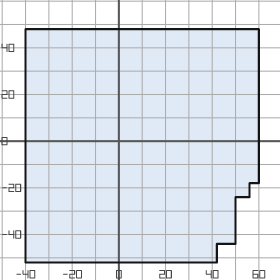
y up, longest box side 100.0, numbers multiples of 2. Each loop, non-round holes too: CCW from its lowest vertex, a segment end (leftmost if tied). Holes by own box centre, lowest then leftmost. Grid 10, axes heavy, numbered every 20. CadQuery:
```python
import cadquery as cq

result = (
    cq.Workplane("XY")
    .moveTo(-40.0, -52.0)
    .lineTo(42.0, -52.0)
    .lineTo(42.0, -44.0)
    .lineTo(50.0, -44.0)
    .lineTo(50.0, -24.0)
    .lineTo(56.0, -24.0)
    .lineTo(56.0, -18.0)
    .lineTo(60.0, -18.0)
    .lineTo(60.0, 48.0)
    .lineTo(-40.0, 48.0)
    .close()
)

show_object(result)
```